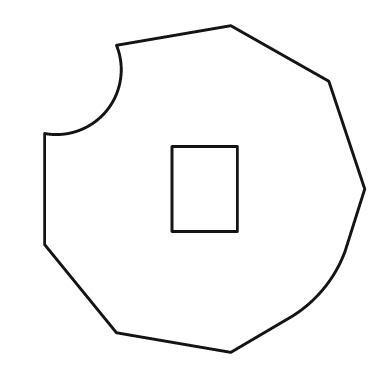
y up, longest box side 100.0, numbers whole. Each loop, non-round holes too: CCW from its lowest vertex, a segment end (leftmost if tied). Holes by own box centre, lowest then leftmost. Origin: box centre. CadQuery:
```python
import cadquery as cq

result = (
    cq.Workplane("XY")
    .moveTo(8.0, -50.0)
    .lineTo(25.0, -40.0)
    .threePointArc((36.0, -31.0), (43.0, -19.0))
    .lineTo(49.0, 0.0)
    .lineTo(38.0, 33.0)
    .lineTo(8.0, 50.0)
    .lineTo(-27.0, 44.0)
    .threePointArc((-30.0, 24.0), (-49.0, 17.0))
    .lineTo(-49.0, -17.0)
    .lineTo(-27.0, -44.0)
    .close()
    .moveTo(-10.0, -13.0)
    .lineTo(10.0, -13.0)
    .lineTo(10.0, 13.0)
    .lineTo(-10.0, 13.0)
    .close()
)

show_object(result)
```